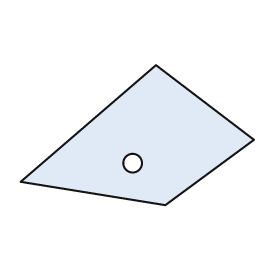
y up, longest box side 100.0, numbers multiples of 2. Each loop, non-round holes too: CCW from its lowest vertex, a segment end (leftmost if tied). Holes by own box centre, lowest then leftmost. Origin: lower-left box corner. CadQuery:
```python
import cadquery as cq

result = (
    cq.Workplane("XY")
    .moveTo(62.0, 0.0)
    .lineTo(100.0, 28.0)
    .lineTo(58.0, 60.0)
    .lineTo(0.0, 10.0)
    .close()
    .moveTo(48.0, 18.0)
    .circle(4.0)
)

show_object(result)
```